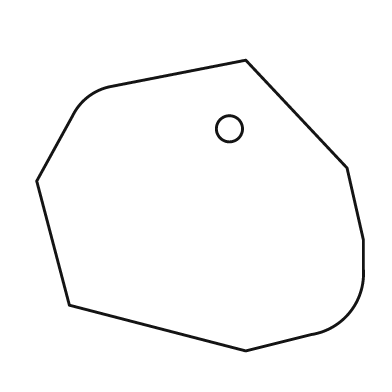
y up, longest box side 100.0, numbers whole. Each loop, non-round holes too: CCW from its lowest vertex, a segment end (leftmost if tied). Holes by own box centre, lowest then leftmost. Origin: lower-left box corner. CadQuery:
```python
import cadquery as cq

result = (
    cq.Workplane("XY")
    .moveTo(64.0, 0.0)
    .lineTo(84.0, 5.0)
    .threePointArc((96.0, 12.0), (100.0, 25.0))
    .lineTo(100.0, 34.0)
    .lineTo(95.0, 56.0)
    .lineTo(64.0, 89.0)
    .lineTo(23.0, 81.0)
    .threePointArc((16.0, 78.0), (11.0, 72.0))
    .lineTo(0.0, 52.0)
    .lineTo(10.0, 14.0)
    .close()
    .moveTo(59.0, 68.0)
    .circle(4.0)
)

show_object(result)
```